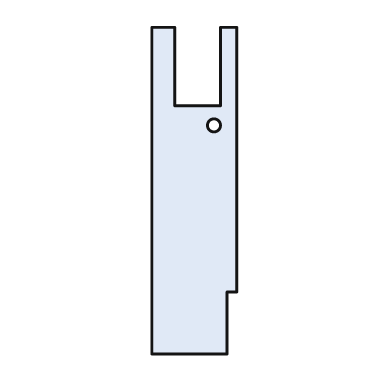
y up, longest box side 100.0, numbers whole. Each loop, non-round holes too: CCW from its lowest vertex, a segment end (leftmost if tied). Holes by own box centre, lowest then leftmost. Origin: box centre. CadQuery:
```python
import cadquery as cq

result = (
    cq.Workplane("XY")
    .moveTo(-13.0, -50.0)
    .lineTo(10.0, -50.0)
    .lineTo(10.0, -31.0)
    .lineTo(13.0, -31.0)
    .lineTo(13.0, 50.0)
    .lineTo(8.0, 50.0)
    .lineTo(8.0, 26.0)
    .lineTo(-6.0, 26.0)
    .lineTo(-6.0, 50.0)
    .lineTo(-13.0, 50.0)
    .close()
    .moveTo(6.0, 20.0)
    .circle(2.0)
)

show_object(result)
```